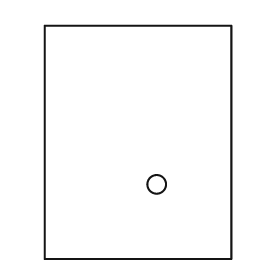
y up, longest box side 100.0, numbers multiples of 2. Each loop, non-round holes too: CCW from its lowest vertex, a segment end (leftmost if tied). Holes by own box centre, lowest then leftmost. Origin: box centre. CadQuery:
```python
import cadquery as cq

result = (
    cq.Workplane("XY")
    .moveTo(-40.0, -50.0)
    .lineTo(40.0, -50.0)
    .lineTo(40.0, 50.0)
    .lineTo(-40.0, 50.0)
    .close()
    .moveTo(8.0, -18.0)
    .circle(4.0)
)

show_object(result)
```